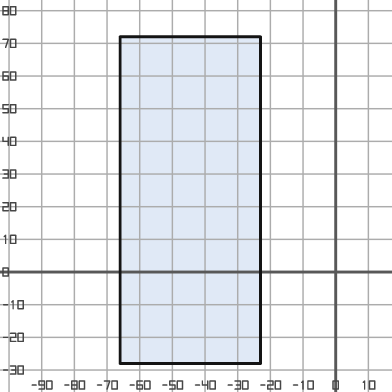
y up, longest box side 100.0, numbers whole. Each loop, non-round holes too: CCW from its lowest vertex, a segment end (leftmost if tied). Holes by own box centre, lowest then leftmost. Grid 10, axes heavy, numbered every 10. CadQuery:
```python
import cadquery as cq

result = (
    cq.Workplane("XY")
    .moveTo(-66.0, -28.0)
    .lineTo(-23.0, -28.0)
    .lineTo(-23.0, 72.0)
    .lineTo(-66.0, 72.0)
    .close()
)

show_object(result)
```